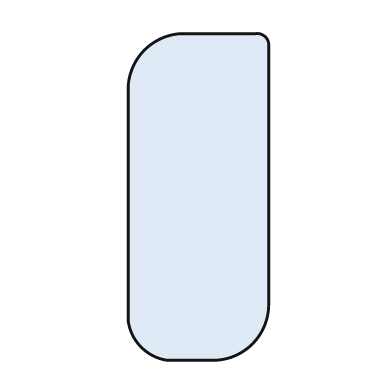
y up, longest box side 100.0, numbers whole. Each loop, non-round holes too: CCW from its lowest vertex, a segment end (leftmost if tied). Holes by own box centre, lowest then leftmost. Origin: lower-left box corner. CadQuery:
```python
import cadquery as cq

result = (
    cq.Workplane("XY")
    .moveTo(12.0, 0.0)
    .lineTo(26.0, 0.0)
    .threePointArc((38.0, 5.0), (43.0, 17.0))
    .lineTo(43.0, 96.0)
    .threePointArc((42.0, 99.0), (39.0, 100.0))
    .lineTo(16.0, 100.0)
    .threePointArc((5.0, 95.0), (0.0, 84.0))
    .lineTo(0.0, 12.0)
    .threePointArc((4.0, 4.0), (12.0, 0.0))
    .close()
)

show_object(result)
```